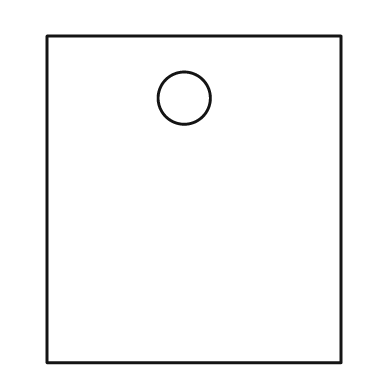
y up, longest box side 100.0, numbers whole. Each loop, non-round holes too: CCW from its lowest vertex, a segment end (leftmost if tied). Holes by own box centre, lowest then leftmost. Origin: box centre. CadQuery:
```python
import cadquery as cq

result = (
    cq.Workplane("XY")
    .moveTo(-45.0, -50.0)
    .lineTo(45.0, -50.0)
    .lineTo(45.0, 50.0)
    .lineTo(-45.0, 50.0)
    .close()
    .moveTo(-3.0, 31.0)
    .circle(8.0)
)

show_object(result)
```